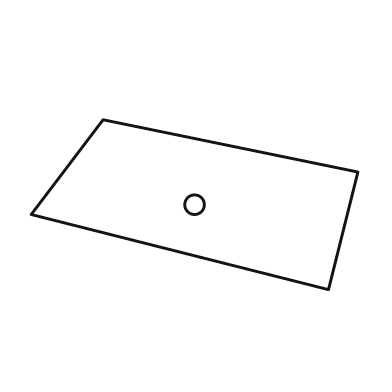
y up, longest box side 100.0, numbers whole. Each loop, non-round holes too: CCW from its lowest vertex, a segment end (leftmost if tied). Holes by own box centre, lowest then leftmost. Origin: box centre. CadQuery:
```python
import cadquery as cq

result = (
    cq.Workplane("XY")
    .moveTo(41.0, -26.0)
    .lineTo(50.0, 10.0)
    .lineTo(-28.0, 26.0)
    .lineTo(-50.0, -3.0)
    .close()
    .moveTo(0.0, 0.0)
    .circle(3.0)
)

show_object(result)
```